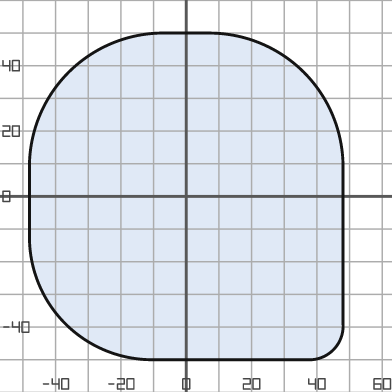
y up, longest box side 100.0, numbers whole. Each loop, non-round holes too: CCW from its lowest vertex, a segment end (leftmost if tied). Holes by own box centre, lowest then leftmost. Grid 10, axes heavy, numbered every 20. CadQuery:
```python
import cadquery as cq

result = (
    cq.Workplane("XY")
    .moveTo(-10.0, -50.0)
    .lineTo(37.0, -50.0)
    .threePointArc((45.0, -47.0), (48.0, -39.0))
    .lineTo(48.0, 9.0)
    .threePointArc((36.0, 38.0), (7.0, 50.0))
    .lineTo(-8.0, 50.0)
    .threePointArc((-36.0, 38.0), (-48.0, 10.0))
    .lineTo(-48.0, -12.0)
    .threePointArc((-37.0, -39.0), (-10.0, -50.0))
    .close()
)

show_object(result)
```